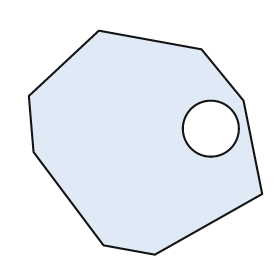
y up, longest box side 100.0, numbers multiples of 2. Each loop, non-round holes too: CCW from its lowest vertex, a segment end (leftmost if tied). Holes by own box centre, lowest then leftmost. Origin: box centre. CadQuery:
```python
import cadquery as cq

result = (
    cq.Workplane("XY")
    .moveTo(4.0, -48.0)
    .lineTo(50.0, -22.0)
    .lineTo(42.0, 18.0)
    .lineTo(24.0, 40.0)
    .lineTo(-20.0, 48.0)
    .lineTo(-50.0, 20.0)
    .lineTo(-48.0, -4.0)
    .lineTo(-18.0, -44.0)
    .close()
    .moveTo(28.0, 6.0)
    .circle(12.0)
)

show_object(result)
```